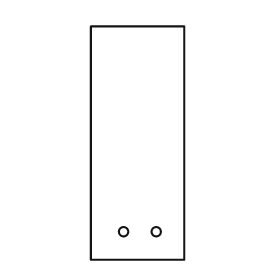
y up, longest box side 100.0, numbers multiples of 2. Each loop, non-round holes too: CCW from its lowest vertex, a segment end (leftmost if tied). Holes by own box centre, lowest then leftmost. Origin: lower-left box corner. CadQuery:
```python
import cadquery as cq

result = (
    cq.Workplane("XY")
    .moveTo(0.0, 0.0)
    .lineTo(40.0, 0.0)
    .lineTo(40.0, 100.0)
    .lineTo(0.0, 100.0)
    .close()
    .moveTo(14.0, 12.0)
    .circle(2.0)
    .moveTo(28.0, 12.0)
    .circle(2.0)
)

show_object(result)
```